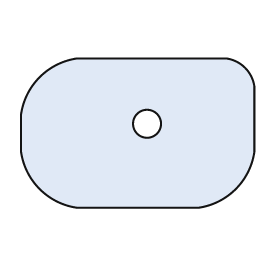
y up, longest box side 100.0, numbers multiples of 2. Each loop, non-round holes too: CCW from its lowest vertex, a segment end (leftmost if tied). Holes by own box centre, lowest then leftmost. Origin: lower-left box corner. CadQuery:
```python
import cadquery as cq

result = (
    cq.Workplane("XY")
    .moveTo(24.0, 0.0)
    .lineTo(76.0, 0.0)
    .threePointArc((92.0, 8.0), (100.0, 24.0))
    .lineTo(100.0, 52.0)
    .threePointArc((96.0, 60.0), (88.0, 64.0))
    .lineTo(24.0, 64.0)
    .threePointArc((8.0, 56.0), (0.0, 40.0))
    .lineTo(0.0, 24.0)
    .threePointArc((8.0, 8.0), (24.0, 0.0))
    .close()
    .moveTo(54.0, 36.0)
    .circle(6.0)
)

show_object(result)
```